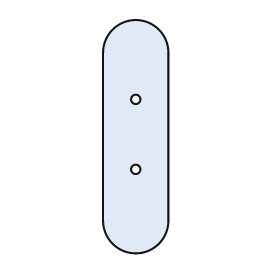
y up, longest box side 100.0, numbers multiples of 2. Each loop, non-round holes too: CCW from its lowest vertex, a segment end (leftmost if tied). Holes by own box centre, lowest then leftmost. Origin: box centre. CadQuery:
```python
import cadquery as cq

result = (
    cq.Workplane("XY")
    .moveTo(-14.0, -36.0)
    .threePointArc((0.0, -50.0), (14.0, -36.0))
    .lineTo(14.0, 36.0)
    .threePointArc((0.0, 50.0), (-14.0, 36.0))
    .close()
    .moveTo(0.0, -14.0)
    .circle(2.0)
    .moveTo(0.0, 16.0)
    .circle(2.0)
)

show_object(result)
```